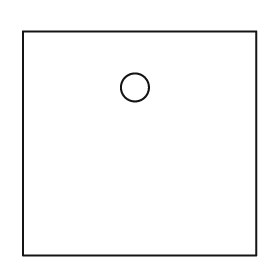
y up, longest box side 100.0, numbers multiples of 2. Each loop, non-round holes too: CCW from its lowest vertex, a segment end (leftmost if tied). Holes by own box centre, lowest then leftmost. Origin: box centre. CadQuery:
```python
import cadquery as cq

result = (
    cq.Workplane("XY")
    .moveTo(-50.0, -48.0)
    .lineTo(50.0, -48.0)
    .lineTo(50.0, 48.0)
    .lineTo(-50.0, 48.0)
    .close()
    .moveTo(-2.0, 24.0)
    .circle(6.0)
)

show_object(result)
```